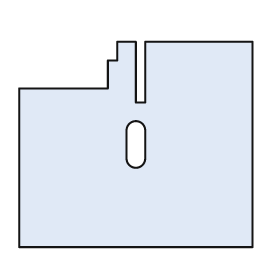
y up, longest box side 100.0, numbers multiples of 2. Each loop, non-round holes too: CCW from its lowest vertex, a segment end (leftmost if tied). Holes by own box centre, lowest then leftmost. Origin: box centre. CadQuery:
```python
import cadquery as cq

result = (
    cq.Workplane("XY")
    .moveTo(-50.0, -44.0)
    .lineTo(50.0, -44.0)
    .lineTo(50.0, 44.0)
    .lineTo(4.0, 44.0)
    .lineTo(4.0, 18.0)
    .lineTo(0.0, 18.0)
    .lineTo(0.0, 44.0)
    .lineTo(-8.0, 44.0)
    .lineTo(-8.0, 36.0)
    .lineTo(-12.0, 36.0)
    .lineTo(-12.0, 24.0)
    .lineTo(-50.0, 24.0)
    .close()
    .moveTo(-4.0, -6.0)
    .threePointArc((0.0, -10.0), (4.0, -6.0))
    .lineTo(4.0, 6.0)
    .threePointArc((0.0, 10.0), (-4.0, 6.0))
    .close()
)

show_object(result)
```